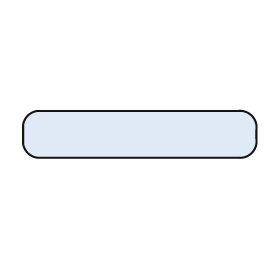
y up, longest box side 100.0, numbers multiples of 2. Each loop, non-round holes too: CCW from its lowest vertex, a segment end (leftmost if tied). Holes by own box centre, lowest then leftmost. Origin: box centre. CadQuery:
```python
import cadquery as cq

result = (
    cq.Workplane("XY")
    .moveTo(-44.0, -10.0)
    .lineTo(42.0, -10.0)
    .threePointArc((48.0, -8.0), (50.0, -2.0))
    .lineTo(50.0, 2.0)
    .threePointArc((48.0, 8.0), (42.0, 10.0))
    .lineTo(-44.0, 10.0)
    .threePointArc((-48.0, 8.0), (-50.0, 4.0))
    .lineTo(-50.0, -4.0)
    .threePointArc((-48.0, -8.0), (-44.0, -10.0))
    .close()
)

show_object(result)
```